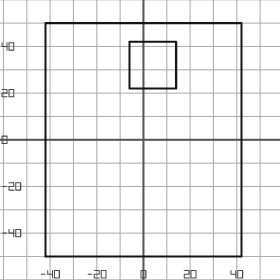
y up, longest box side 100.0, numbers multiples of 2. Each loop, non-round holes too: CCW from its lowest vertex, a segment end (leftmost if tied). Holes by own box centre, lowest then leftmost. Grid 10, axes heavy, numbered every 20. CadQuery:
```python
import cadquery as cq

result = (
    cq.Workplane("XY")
    .moveTo(-42.0, -50.0)
    .lineTo(42.0, -50.0)
    .lineTo(42.0, 50.0)
    .lineTo(-42.0, 50.0)
    .close()
    .moveTo(-6.0, 22.0)
    .lineTo(14.0, 22.0)
    .lineTo(14.0, 42.0)
    .lineTo(-6.0, 42.0)
    .close()
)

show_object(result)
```